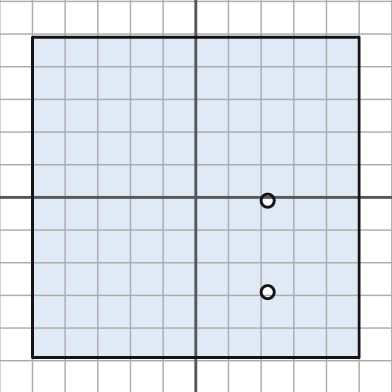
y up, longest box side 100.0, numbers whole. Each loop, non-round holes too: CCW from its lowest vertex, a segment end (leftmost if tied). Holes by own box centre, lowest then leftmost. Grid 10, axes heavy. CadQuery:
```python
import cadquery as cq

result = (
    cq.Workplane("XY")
    .moveTo(-50.0, -49.0)
    .lineTo(50.0, -49.0)
    .lineTo(50.0, 49.0)
    .lineTo(-50.0, 49.0)
    .close()
    .moveTo(22.0, -29.0)
    .circle(2.0)
    .moveTo(22.0, -1.0)
    .circle(2.0)
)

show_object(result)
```